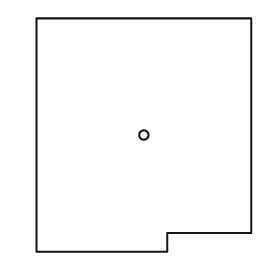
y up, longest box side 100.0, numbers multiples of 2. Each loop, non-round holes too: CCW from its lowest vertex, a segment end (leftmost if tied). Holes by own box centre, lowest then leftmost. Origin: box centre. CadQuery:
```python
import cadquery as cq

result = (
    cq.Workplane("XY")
    .moveTo(-46.0, -50.0)
    .lineTo(10.0, -50.0)
    .lineTo(10.0, -42.0)
    .lineTo(46.0, -42.0)
    .lineTo(46.0, 50.0)
    .lineTo(-46.0, 50.0)
    .close()
    .moveTo(0.0, 0.0)
    .circle(2.0)
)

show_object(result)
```